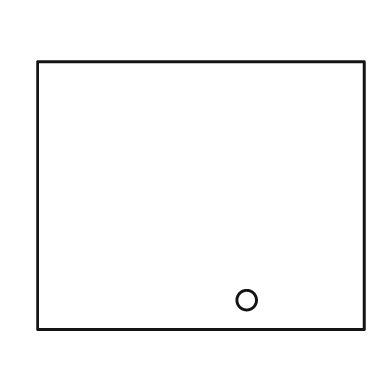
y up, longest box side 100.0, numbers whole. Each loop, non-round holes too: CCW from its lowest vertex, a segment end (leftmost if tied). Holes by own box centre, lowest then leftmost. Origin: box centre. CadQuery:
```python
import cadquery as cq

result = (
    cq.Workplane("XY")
    .moveTo(-50.0, -41.0)
    .lineTo(50.0, -41.0)
    .lineTo(50.0, 41.0)
    .lineTo(-50.0, 41.0)
    .close()
    .moveTo(14.0, -32.0)
    .circle(3.0)
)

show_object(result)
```